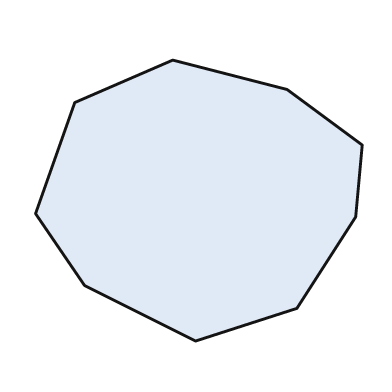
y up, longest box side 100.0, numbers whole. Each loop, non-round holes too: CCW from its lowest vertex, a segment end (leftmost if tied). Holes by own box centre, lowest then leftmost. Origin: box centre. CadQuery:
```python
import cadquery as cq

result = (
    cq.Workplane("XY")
    .moveTo(-1.0, -43.0)
    .lineTo(30.0, -33.0)
    .lineTo(48.0, -5.0)
    .lineTo(50.0, 17.0)
    .lineTo(27.0, 34.0)
    .lineTo(-8.0, 43.0)
    .lineTo(-38.0, 30.0)
    .lineTo(-50.0, -4.0)
    .lineTo(-35.0, -26.0)
    .close()
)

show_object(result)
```